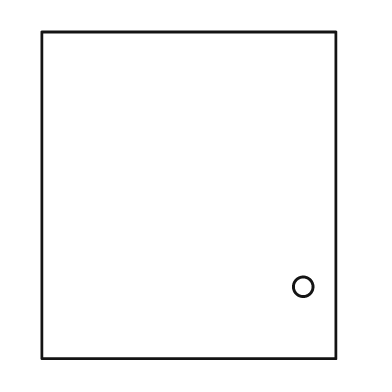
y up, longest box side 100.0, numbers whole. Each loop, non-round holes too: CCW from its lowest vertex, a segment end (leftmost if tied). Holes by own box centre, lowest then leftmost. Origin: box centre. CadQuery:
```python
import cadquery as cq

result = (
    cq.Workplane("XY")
    .moveTo(-45.0, -50.0)
    .lineTo(45.0, -50.0)
    .lineTo(45.0, 50.0)
    .lineTo(-45.0, 50.0)
    .close()
    .moveTo(35.0, -28.0)
    .circle(3.0)
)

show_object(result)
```